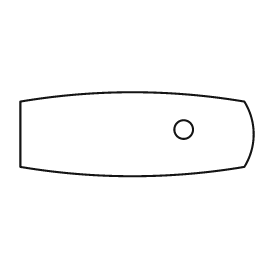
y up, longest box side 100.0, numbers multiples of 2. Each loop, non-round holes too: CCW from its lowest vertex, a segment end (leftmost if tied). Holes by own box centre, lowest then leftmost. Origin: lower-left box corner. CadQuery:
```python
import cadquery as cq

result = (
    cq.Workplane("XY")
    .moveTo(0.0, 4.0)
    .threePointArc((48.0, 0.0), (96.0, 4.0))
    .threePointArc((100.0, 18.0), (96.0, 32.0))
    .threePointArc((48.0, 36.0), (0.0, 32.0))
    .close()
    .moveTo(70.0, 20.0)
    .circle(4.0)
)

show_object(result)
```